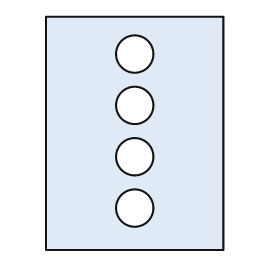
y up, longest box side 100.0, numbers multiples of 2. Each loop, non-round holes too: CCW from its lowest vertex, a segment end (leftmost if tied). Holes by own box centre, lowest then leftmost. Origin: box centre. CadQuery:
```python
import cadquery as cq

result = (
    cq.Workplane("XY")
    .moveTo(-38.0, -50.0)
    .lineTo(38.0, -50.0)
    .lineTo(38.0, 50.0)
    .lineTo(-38.0, 50.0)
    .close()
    .moveTo(0.0, -32.0)
    .circle(8.0)
    .moveTo(0.0, -10.0)
    .circle(8.0)
    .moveTo(0.0, 12.0)
    .circle(8.0)
    .moveTo(0.0, 34.0)
    .circle(8.0)
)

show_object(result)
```